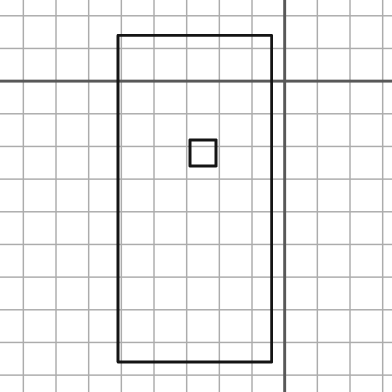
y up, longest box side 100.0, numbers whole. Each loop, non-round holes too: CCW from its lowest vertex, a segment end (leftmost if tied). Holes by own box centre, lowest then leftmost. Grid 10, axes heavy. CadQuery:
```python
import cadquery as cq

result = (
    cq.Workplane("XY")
    .moveTo(-51.0, -86.0)
    .lineTo(-4.0, -86.0)
    .lineTo(-4.0, 14.0)
    .lineTo(-51.0, 14.0)
    .close()
    .moveTo(-29.0, -26.0)
    .lineTo(-21.0, -26.0)
    .lineTo(-21.0, -18.0)
    .lineTo(-29.0, -18.0)
    .close()
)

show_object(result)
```